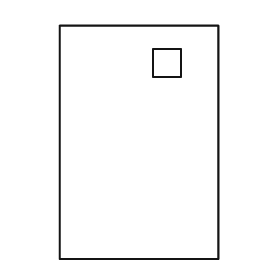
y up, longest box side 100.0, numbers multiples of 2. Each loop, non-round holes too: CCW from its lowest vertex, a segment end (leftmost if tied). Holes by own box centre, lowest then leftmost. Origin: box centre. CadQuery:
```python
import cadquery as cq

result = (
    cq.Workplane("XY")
    .moveTo(-34.0, -50.0)
    .lineTo(34.0, -50.0)
    .lineTo(34.0, 50.0)
    .lineTo(-34.0, 50.0)
    .close()
    .moveTo(6.0, 28.0)
    .lineTo(18.0, 28.0)
    .lineTo(18.0, 40.0)
    .lineTo(6.0, 40.0)
    .close()
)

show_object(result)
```